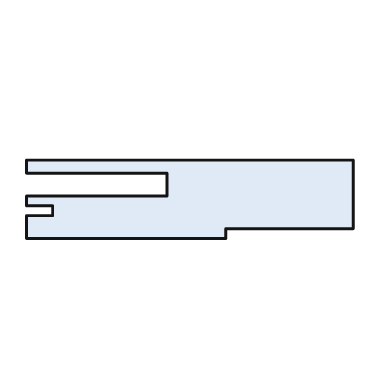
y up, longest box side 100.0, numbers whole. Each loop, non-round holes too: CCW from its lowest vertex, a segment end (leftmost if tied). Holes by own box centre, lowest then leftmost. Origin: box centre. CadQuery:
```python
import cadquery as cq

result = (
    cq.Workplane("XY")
    .moveTo(-50.0, -12.0)
    .lineTo(11.0, -12.0)
    .lineTo(11.0, -9.0)
    .lineTo(50.0, -9.0)
    .lineTo(50.0, 12.0)
    .lineTo(-50.0, 12.0)
    .lineTo(-50.0, 8.0)
    .lineTo(-7.0, 8.0)
    .lineTo(-7.0, 1.0)
    .lineTo(-50.0, 1.0)
    .lineTo(-50.0, -2.0)
    .lineTo(-42.0, -2.0)
    .lineTo(-42.0, -5.0)
    .lineTo(-50.0, -5.0)
    .close()
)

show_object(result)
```